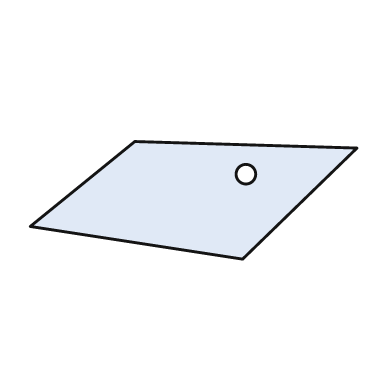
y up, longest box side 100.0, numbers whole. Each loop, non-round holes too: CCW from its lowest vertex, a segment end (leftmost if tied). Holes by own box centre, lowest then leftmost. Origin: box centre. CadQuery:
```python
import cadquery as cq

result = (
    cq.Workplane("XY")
    .moveTo(15.0, -18.0)
    .lineTo(50.0, 16.0)
    .lineTo(-18.0, 18.0)
    .lineTo(-50.0, -8.0)
    .close()
    .moveTo(16.0, 8.0)
    .circle(3.0)
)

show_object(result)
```